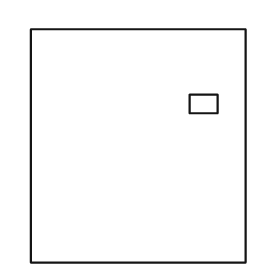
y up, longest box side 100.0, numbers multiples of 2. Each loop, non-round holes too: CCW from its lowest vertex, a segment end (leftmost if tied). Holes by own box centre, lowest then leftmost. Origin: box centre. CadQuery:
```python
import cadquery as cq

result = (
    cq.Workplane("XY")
    .moveTo(-46.0, -50.0)
    .lineTo(46.0, -50.0)
    .lineTo(46.0, 50.0)
    .lineTo(-46.0, 50.0)
    .close()
    .moveTo(22.0, 14.0)
    .lineTo(34.0, 14.0)
    .lineTo(34.0, 22.0)
    .lineTo(22.0, 22.0)
    .close()
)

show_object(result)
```